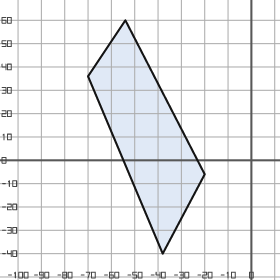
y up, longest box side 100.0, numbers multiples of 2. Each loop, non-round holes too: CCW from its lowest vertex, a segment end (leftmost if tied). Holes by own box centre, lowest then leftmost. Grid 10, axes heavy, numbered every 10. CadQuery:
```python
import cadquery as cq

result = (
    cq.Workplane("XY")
    .moveTo(-38.0, -40.0)
    .lineTo(-20.0, -6.0)
    .lineTo(-54.0, 60.0)
    .lineTo(-70.0, 36.0)
    .close()
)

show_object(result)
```